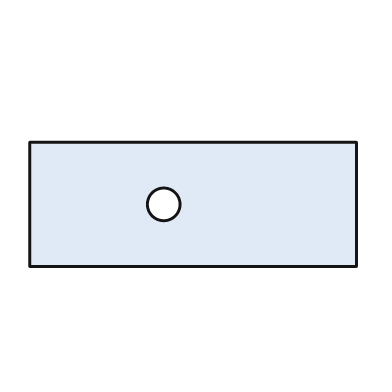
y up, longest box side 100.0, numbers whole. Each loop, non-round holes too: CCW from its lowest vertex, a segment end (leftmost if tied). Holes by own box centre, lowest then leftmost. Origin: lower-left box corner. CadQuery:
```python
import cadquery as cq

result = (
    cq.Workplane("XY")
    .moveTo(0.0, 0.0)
    .lineTo(100.0, 0.0)
    .lineTo(100.0, 38.0)
    .lineTo(0.0, 38.0)
    .close()
    .moveTo(41.0, 19.0)
    .circle(5.0)
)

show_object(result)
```